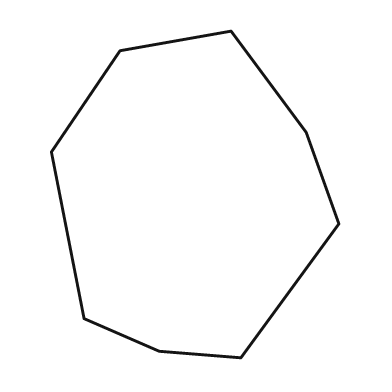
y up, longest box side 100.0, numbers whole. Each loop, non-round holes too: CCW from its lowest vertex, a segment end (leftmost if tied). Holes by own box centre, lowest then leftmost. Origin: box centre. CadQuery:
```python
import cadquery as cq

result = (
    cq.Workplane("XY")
    .moveTo(14.0, -50.0)
    .lineTo(44.0, -9.0)
    .lineTo(34.0, 19.0)
    .lineTo(11.0, 50.0)
    .lineTo(-23.0, 44.0)
    .lineTo(-44.0, 13.0)
    .lineTo(-34.0, -38.0)
    .lineTo(-11.0, -48.0)
    .close()
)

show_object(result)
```